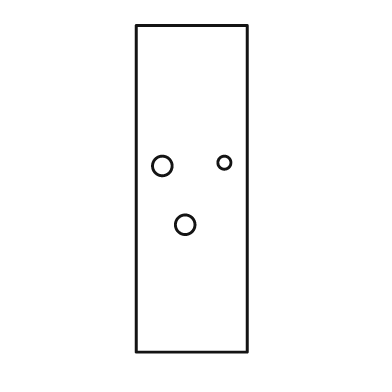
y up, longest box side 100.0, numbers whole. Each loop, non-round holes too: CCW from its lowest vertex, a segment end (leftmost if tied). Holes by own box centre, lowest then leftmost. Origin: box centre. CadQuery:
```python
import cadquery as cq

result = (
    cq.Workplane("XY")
    .moveTo(-17.0, -50.0)
    .lineTo(17.0, -50.0)
    .lineTo(17.0, 50.0)
    .lineTo(-17.0, 50.0)
    .close()
    .moveTo(-2.0, -11.0)
    .circle(3.0)
    .moveTo(-9.0, 7.0)
    .circle(3.0)
    .moveTo(10.0, 8.0)
    .circle(2.0)
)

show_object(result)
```